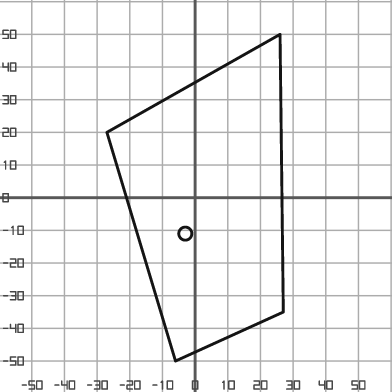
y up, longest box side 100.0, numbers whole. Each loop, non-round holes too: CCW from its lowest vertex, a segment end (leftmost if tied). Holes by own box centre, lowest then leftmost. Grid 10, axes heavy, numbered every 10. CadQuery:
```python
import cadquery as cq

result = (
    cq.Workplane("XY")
    .moveTo(-6.0, -50.0)
    .lineTo(27.0, -35.0)
    .lineTo(26.0, 50.0)
    .lineTo(-27.0, 20.0)
    .close()
    .moveTo(-3.0, -11.0)
    .circle(2.0)
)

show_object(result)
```